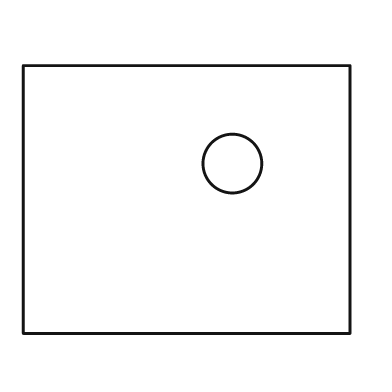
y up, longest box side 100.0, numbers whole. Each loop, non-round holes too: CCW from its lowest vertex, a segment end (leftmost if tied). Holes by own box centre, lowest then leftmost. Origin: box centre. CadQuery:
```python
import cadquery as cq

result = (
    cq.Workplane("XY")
    .moveTo(-50.0, -41.0)
    .lineTo(50.0, -41.0)
    .lineTo(50.0, 41.0)
    .lineTo(-50.0, 41.0)
    .close()
    .moveTo(14.0, 11.0)
    .circle(9.0)
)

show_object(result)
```